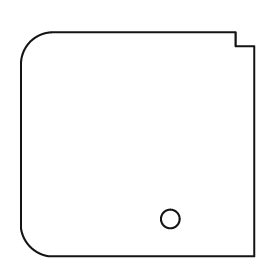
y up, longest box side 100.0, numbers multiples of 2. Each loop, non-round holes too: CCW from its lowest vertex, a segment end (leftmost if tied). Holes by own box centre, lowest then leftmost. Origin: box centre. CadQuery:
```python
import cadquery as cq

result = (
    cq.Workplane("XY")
    .moveTo(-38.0, -48.0)
    .lineTo(50.0, -48.0)
    .lineTo(50.0, 42.0)
    .lineTo(42.0, 42.0)
    .lineTo(42.0, 48.0)
    .lineTo(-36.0, 48.0)
    .threePointArc((-46.0, 44.0), (-50.0, 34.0))
    .lineTo(-50.0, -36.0)
    .threePointArc((-46.0, -44.0), (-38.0, -48.0))
    .close()
    .moveTo(14.0, -32.0)
    .circle(4.0)
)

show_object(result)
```